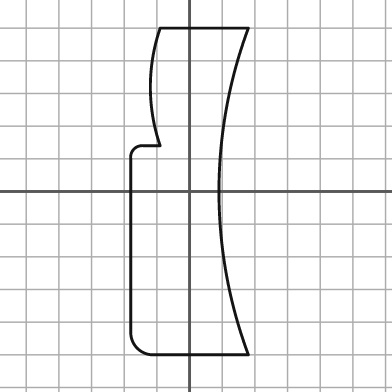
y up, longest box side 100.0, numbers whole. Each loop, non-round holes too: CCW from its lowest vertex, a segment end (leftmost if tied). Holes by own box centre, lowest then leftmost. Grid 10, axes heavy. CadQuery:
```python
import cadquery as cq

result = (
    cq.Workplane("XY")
    .moveTo(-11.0, -50.0)
    .lineTo(18.0, -50.0)
    .threePointArc((9.0, 0.0), (18.0, 50.0))
    .lineTo(-9.0, 50.0)
    .threePointArc((-12.0, 32.0), (-9.0, 14.0))
    .lineTo(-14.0, 14.0)
    .threePointArc((-17.0, 13.0), (-18.0, 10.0))
    .lineTo(-18.0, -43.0)
    .threePointArc((-16.0, -48.0), (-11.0, -50.0))
    .close()
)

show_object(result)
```